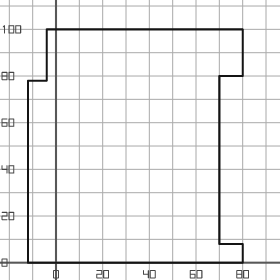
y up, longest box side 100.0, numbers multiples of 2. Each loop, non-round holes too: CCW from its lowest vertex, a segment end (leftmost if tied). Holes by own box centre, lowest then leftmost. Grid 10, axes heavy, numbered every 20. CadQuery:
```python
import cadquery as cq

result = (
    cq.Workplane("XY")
    .moveTo(-12.0, 0.0)
    .lineTo(80.0, 0.0)
    .lineTo(80.0, 8.0)
    .lineTo(70.0, 8.0)
    .lineTo(70.0, 80.0)
    .lineTo(80.0, 80.0)
    .lineTo(80.0, 100.0)
    .lineTo(-4.0, 100.0)
    .lineTo(-4.0, 78.0)
    .lineTo(-12.0, 78.0)
    .close()
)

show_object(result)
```